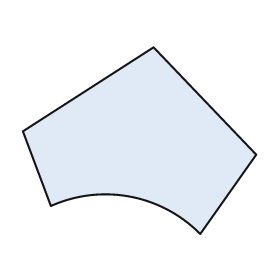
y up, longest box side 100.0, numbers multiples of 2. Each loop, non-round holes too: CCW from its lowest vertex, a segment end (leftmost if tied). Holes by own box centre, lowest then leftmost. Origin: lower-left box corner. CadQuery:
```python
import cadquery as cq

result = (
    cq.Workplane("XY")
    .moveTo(76.0, 0.0)
    .lineTo(100.0, 34.0)
    .lineTo(56.0, 80.0)
    .lineTo(0.0, 44.0)
    .lineTo(12.0, 12.0)
    .threePointArc((46.0, 16.0), (76.0, 0.0))
    .close()
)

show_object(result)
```